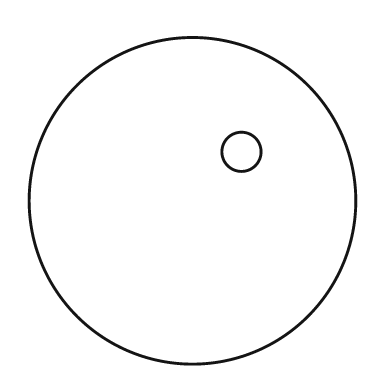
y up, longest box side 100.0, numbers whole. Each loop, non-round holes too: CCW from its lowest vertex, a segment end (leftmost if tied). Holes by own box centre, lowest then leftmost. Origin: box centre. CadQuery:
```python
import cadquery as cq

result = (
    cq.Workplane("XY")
    .moveTo(0.0, 0.0)
    .circle(50.0)
    .moveTo(15.0, 15.0)
    .circle(6.0)
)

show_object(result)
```